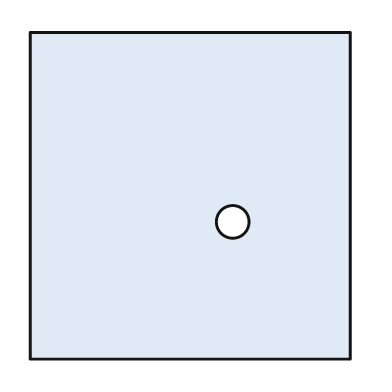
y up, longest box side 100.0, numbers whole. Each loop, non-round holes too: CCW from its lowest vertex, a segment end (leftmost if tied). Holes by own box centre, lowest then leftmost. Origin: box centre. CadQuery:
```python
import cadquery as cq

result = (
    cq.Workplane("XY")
    .moveTo(-49.0, -50.0)
    .lineTo(49.0, -50.0)
    .lineTo(49.0, 50.0)
    .lineTo(-49.0, 50.0)
    .close()
    .moveTo(13.0, -8.0)
    .circle(5.0)
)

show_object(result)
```